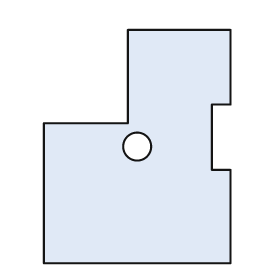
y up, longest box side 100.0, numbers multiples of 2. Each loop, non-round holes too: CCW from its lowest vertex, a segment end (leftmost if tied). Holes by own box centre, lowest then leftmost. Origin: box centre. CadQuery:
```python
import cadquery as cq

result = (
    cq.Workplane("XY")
    .moveTo(-40.0, -50.0)
    .lineTo(40.0, -50.0)
    .lineTo(40.0, -10.0)
    .lineTo(32.0, -10.0)
    .lineTo(32.0, 18.0)
    .lineTo(40.0, 18.0)
    .lineTo(40.0, 50.0)
    .lineTo(-4.0, 50.0)
    .lineTo(-4.0, 10.0)
    .lineTo(-40.0, 10.0)
    .close()
    .moveTo(0.0, 0.0)
    .circle(6.0)
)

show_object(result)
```